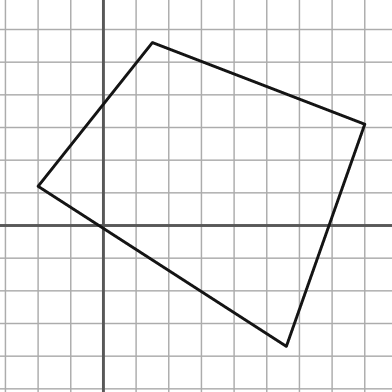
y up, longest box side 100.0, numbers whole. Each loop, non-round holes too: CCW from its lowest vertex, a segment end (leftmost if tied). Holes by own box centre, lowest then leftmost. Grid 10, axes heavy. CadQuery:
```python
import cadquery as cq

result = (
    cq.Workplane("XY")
    .moveTo(56.0, -37.0)
    .lineTo(80.0, 31.0)
    .lineTo(15.0, 56.0)
    .lineTo(-20.0, 12.0)
    .close()
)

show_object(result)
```